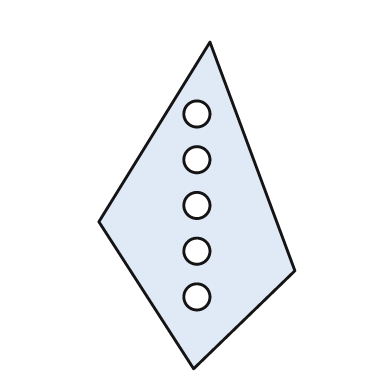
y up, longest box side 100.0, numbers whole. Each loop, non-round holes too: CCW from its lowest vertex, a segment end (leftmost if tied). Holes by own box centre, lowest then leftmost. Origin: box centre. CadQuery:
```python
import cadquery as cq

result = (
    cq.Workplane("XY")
    .moveTo(-1.0, -50.0)
    .lineTo(30.0, -20.0)
    .lineTo(4.0, 50.0)
    .lineTo(-30.0, -5.0)
    .close()
    .moveTo(0.0, -28.0)
    .circle(4.0)
    .moveTo(0.0, -14.0)
    .circle(4.0)
    .moveTo(0.0, 0.0)
    .circle(4.0)
    .moveTo(0.0, 14.0)
    .circle(4.0)
    .moveTo(0.0, 28.0)
    .circle(4.0)
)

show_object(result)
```